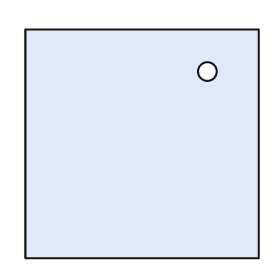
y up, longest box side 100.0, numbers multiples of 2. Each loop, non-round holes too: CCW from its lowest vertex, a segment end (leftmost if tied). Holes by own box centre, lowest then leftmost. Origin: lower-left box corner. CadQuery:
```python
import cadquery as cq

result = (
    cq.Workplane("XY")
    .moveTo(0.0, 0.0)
    .lineTo(100.0, 0.0)
    .lineTo(100.0, 98.0)
    .lineTo(0.0, 98.0)
    .close()
    .moveTo(78.0, 80.0)
    .circle(4.0)
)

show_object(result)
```